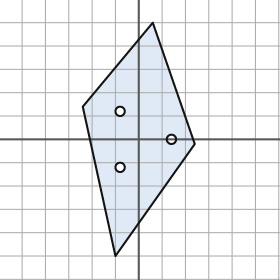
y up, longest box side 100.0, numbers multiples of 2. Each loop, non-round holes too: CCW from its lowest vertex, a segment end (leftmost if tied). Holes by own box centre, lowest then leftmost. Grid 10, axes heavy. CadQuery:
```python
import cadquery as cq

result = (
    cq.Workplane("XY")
    .moveTo(-10.0, -50.0)
    .lineTo(24.0, -2.0)
    .lineTo(6.0, 50.0)
    .lineTo(-24.0, 14.0)
    .close()
    .moveTo(-8.0, -12.0)
    .circle(2.0)
    .moveTo(14.0, 0.0)
    .circle(2.0)
    .moveTo(-8.0, 12.0)
    .circle(2.0)
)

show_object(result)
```